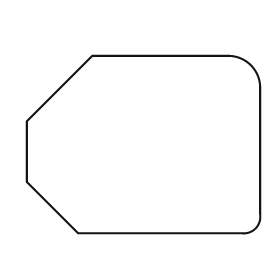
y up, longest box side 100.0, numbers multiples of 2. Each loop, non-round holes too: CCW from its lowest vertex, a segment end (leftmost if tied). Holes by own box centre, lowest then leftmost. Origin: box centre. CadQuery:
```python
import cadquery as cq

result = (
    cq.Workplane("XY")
    .moveTo(-28.0, -38.0)
    .lineTo(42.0, -38.0)
    .threePointArc((48.0, -36.0), (50.0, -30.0))
    .lineTo(50.0, 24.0)
    .threePointArc((46.0, 34.0), (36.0, 38.0))
    .lineTo(-22.0, 38.0)
    .lineTo(-50.0, 10.0)
    .lineTo(-50.0, -16.0)
    .close()
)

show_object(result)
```